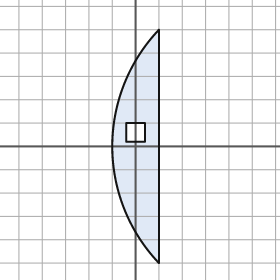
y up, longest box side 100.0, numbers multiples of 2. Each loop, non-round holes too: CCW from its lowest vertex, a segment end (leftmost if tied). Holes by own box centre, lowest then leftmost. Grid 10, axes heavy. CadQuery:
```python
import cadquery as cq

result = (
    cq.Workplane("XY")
    .moveTo(10.0, -50.0)
    .lineTo(10.0, 50.0)
    .threePointArc((-10.0, 0.0), (10.0, -50.0))
    .close()
    .moveTo(-4.0, 2.0)
    .lineTo(4.0, 2.0)
    .lineTo(4.0, 10.0)
    .lineTo(-4.0, 10.0)
    .close()
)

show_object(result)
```